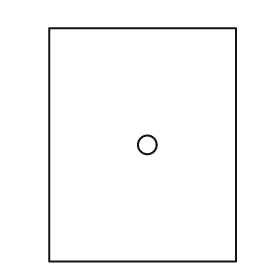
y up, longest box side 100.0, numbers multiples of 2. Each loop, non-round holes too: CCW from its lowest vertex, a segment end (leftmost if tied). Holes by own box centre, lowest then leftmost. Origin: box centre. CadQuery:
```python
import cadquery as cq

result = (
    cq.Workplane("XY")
    .moveTo(-40.0, -50.0)
    .lineTo(40.0, -50.0)
    .lineTo(40.0, 50.0)
    .lineTo(-40.0, 50.0)
    .close()
    .moveTo(2.0, 0.0)
    .circle(4.0)
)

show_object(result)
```